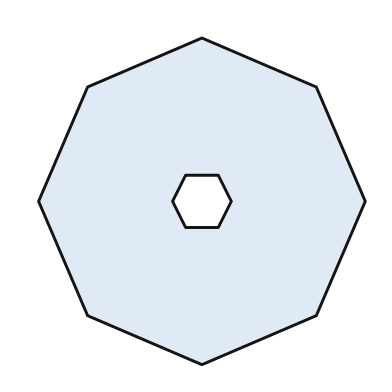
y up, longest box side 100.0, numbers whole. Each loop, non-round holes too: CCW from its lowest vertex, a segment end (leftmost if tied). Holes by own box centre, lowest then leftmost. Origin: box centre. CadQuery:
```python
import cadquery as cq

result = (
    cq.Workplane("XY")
    .moveTo(0.0, -50.0)
    .lineTo(35.0, -35.0)
    .lineTo(50.0, 0.0)
    .lineTo(35.0, 35.0)
    .lineTo(0.0, 50.0)
    .lineTo(-35.0, 35.0)
    .lineTo(-50.0, 0.0)
    .lineTo(-35.0, -35.0)
    .close()
    .moveTo(-5.0, -8.0)
    .lineTo(5.0, -8.0)
    .lineTo(9.0, 0.0)
    .lineTo(5.0, 8.0)
    .lineTo(-5.0, 8.0)
    .lineTo(-9.0, 0.0)
    .close()
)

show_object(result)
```